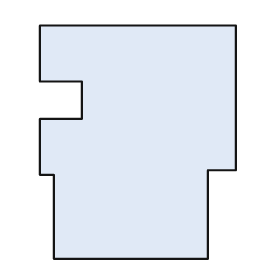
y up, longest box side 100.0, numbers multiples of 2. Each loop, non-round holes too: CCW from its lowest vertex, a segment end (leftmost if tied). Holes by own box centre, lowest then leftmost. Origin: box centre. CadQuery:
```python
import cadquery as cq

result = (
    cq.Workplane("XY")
    .moveTo(-36.0, -50.0)
    .lineTo(30.0, -50.0)
    .lineTo(30.0, -12.0)
    .lineTo(42.0, -12.0)
    .lineTo(42.0, 50.0)
    .lineTo(-42.0, 50.0)
    .lineTo(-42.0, 26.0)
    .lineTo(-24.0, 26.0)
    .lineTo(-24.0, 10.0)
    .lineTo(-42.0, 10.0)
    .lineTo(-42.0, -14.0)
    .lineTo(-36.0, -14.0)
    .close()
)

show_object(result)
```